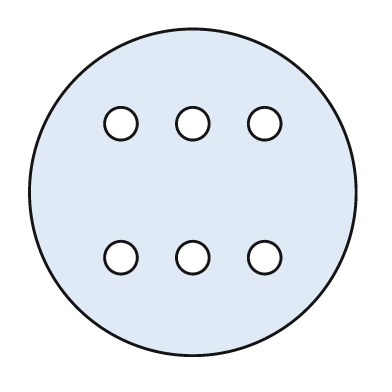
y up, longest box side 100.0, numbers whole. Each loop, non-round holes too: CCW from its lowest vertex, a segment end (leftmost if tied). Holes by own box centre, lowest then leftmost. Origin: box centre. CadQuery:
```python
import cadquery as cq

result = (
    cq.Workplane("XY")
    .moveTo(0.0, 0.0)
    .circle(50.0)
    .moveTo(-22.0, -20.0)
    .circle(5.0)
    .moveTo(0.0, -20.0)
    .circle(5.0)
    .moveTo(22.0, -20.0)
    .circle(5.0)
    .moveTo(-22.0, 21.0)
    .circle(5.0)
    .moveTo(0.0, 21.0)
    .circle(5.0)
    .moveTo(22.0, 21.0)
    .circle(5.0)
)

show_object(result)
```